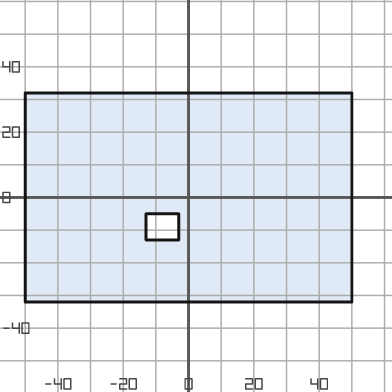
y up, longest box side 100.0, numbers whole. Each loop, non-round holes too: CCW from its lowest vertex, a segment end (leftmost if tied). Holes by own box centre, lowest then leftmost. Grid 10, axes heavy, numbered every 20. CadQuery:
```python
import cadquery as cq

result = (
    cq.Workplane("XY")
    .moveTo(-50.0, -32.0)
    .lineTo(50.0, -32.0)
    .lineTo(50.0, 32.0)
    .lineTo(-50.0, 32.0)
    .close()
    .moveTo(-13.0, -13.0)
    .lineTo(-3.0, -13.0)
    .lineTo(-3.0, -5.0)
    .lineTo(-13.0, -5.0)
    .close()
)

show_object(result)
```